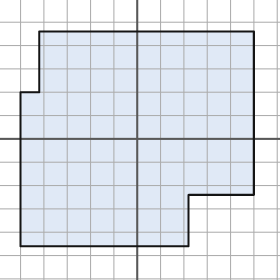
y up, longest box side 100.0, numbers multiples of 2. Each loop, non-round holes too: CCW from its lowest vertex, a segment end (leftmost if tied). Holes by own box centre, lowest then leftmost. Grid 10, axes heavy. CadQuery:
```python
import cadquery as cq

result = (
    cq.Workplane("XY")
    .moveTo(-50.0, -46.0)
    .lineTo(22.0, -46.0)
    .lineTo(22.0, -24.0)
    .lineTo(50.0, -24.0)
    .lineTo(50.0, 46.0)
    .lineTo(-42.0, 46.0)
    .lineTo(-42.0, 20.0)
    .lineTo(-50.0, 20.0)
    .close()
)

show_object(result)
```